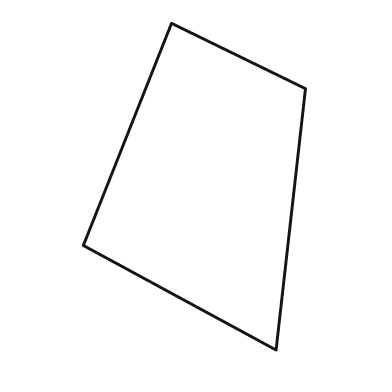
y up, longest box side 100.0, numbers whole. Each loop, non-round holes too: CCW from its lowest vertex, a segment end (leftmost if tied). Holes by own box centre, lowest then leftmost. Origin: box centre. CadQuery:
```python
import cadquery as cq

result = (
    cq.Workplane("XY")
    .moveTo(25.0, -50.0)
    .lineTo(34.0, 30.0)
    .lineTo(-7.0, 50.0)
    .lineTo(-34.0, -18.0)
    .close()
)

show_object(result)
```